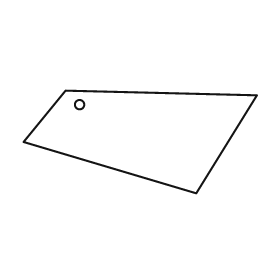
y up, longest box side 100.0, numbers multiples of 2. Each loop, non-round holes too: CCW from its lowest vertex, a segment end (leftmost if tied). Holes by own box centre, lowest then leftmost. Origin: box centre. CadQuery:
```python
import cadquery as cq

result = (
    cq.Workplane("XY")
    .moveTo(24.0, -22.0)
    .lineTo(50.0, 20.0)
    .lineTo(-32.0, 22.0)
    .lineTo(-50.0, 0.0)
    .close()
    .moveTo(-26.0, 16.0)
    .circle(2.0)
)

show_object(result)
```